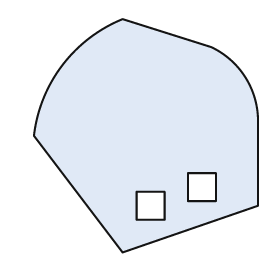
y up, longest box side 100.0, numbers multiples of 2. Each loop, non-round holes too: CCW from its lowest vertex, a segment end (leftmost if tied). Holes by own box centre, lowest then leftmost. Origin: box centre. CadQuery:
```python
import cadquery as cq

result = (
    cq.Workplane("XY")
    .moveTo(-10.0, -50.0)
    .lineTo(48.0, -30.0)
    .lineTo(48.0, 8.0)
    .threePointArc((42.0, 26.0), (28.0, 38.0))
    .lineTo(-10.0, 50.0)
    .threePointArc((-36.0, 30.0), (-48.0, 0.0))
    .close()
    .moveTo(-4.0, -36.0)
    .lineTo(8.0, -36.0)
    .lineTo(8.0, -24.0)
    .lineTo(-4.0, -24.0)
    .close()
    .moveTo(18.0, -28.0)
    .lineTo(30.0, -28.0)
    .lineTo(30.0, -16.0)
    .lineTo(18.0, -16.0)
    .close()
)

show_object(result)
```